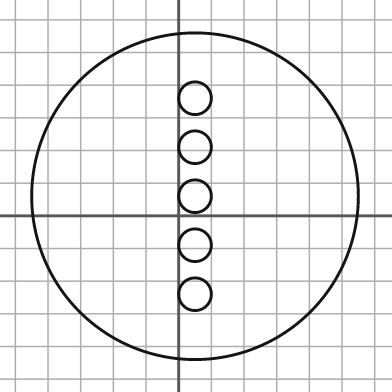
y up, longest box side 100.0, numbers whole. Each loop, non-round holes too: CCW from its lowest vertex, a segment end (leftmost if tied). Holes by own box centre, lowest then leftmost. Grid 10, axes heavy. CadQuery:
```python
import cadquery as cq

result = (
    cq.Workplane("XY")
    .moveTo(5.0, 6.0)
    .circle(50.0)
    .moveTo(5.0, -24.0)
    .circle(5.0)
    .moveTo(5.0, -9.0)
    .circle(5.0)
    .moveTo(5.0, 6.0)
    .circle(5.0)
    .moveTo(5.0, 21.0)
    .circle(5.0)
    .moveTo(5.0, 36.0)
    .circle(5.0)
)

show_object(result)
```